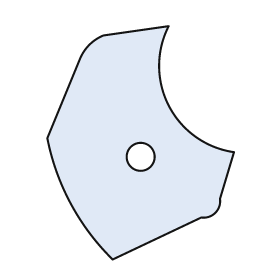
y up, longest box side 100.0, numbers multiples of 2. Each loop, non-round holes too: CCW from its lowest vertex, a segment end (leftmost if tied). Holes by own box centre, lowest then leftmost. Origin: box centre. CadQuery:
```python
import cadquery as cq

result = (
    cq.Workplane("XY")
    .moveTo(-12.0, -50.0)
    .lineTo(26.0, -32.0)
    .threePointArc((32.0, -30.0), (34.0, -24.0))
    .lineTo(40.0, -4.0)
    .threePointArc((12.0, 16.0), (12.0, 50.0))
    .lineTo(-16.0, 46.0)
    .threePointArc((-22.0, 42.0), (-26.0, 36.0))
    .lineTo(-40.0, 2.0)
    .threePointArc((-30.0, -26.0), (-12.0, -50.0))
    .close()
    .moveTo(0.0, -6.0)
    .circle(6.0)
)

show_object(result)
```